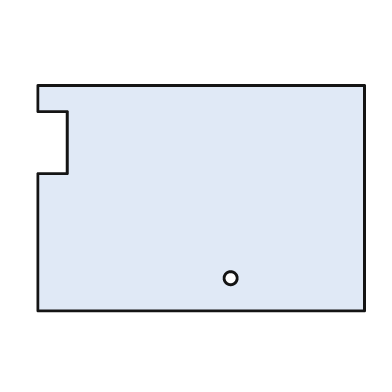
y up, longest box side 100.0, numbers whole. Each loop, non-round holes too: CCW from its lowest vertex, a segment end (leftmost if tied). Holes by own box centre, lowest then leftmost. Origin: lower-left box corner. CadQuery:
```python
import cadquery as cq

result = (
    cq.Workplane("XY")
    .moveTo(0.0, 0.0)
    .lineTo(100.0, 0.0)
    .lineTo(100.0, 69.0)
    .lineTo(0.0, 69.0)
    .lineTo(0.0, 61.0)
    .lineTo(9.0, 61.0)
    .lineTo(9.0, 42.0)
    .lineTo(0.0, 42.0)
    .close()
    .moveTo(59.0, 10.0)
    .circle(2.0)
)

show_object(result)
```